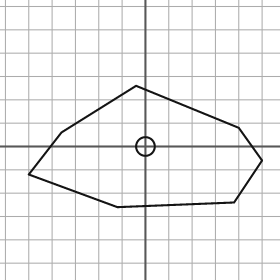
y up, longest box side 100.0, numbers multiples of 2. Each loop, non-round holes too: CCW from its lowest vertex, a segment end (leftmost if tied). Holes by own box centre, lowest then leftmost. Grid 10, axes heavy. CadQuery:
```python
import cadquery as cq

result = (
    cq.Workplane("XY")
    .moveTo(-12.0, -26.0)
    .lineTo(38.0, -24.0)
    .lineTo(50.0, -6.0)
    .lineTo(40.0, 8.0)
    .lineTo(-4.0, 26.0)
    .lineTo(-36.0, 6.0)
    .lineTo(-50.0, -12.0)
    .close()
    .moveTo(0.0, 0.0)
    .circle(4.0)
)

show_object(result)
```